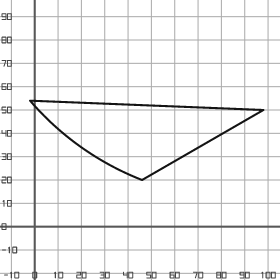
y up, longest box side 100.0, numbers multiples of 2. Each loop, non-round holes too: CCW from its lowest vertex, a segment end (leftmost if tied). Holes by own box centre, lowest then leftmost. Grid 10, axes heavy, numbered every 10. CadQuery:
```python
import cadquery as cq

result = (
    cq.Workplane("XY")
    .moveTo(46.0, 20.0)
    .lineTo(98.0, 50.0)
    .lineTo(-2.0, 54.0)
    .threePointArc((20.0, 34.0), (46.0, 20.0))
    .close()
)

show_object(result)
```